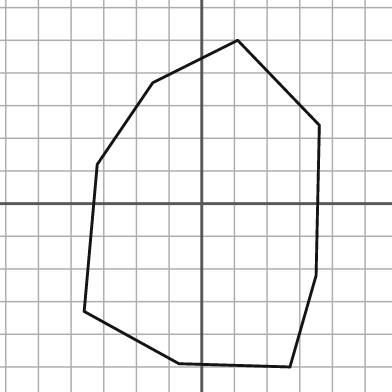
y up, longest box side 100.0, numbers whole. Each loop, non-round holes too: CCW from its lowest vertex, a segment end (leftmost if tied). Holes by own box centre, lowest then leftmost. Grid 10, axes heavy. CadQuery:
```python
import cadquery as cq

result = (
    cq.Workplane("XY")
    .moveTo(27.0, -50.0)
    .lineTo(35.0, -22.0)
    .lineTo(36.0, 24.0)
    .lineTo(11.0, 50.0)
    .lineTo(-15.0, 37.0)
    .lineTo(-32.0, 12.0)
    .lineTo(-36.0, -33.0)
    .lineTo(-7.0, -49.0)
    .close()
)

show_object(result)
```